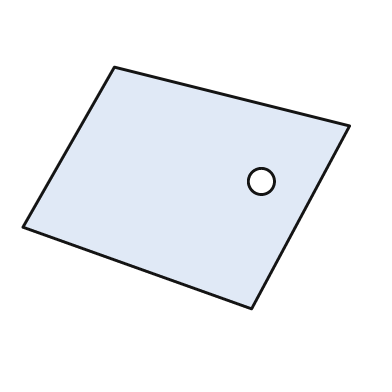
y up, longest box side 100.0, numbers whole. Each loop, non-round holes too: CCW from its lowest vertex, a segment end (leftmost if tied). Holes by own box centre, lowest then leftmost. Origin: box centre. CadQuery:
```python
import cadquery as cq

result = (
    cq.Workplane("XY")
    .moveTo(20.0, -37.0)
    .lineTo(50.0, 19.0)
    .lineTo(-22.0, 37.0)
    .lineTo(-50.0, -12.0)
    .close()
    .moveTo(23.0, 2.0)
    .circle(4.0)
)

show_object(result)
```